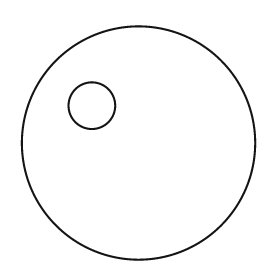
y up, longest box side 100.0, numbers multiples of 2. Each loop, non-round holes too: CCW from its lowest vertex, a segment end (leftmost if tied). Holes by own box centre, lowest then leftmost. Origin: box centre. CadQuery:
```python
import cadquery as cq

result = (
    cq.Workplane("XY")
    .moveTo(0.0, 0.0)
    .circle(50.0)
    .moveTo(-20.0, 16.0)
    .circle(10.0)
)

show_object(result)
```